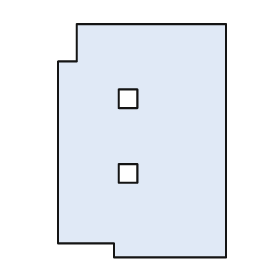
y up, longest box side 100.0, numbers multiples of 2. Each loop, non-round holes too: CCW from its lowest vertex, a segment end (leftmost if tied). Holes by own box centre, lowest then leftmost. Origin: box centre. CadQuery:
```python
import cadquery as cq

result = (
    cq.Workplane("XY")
    .moveTo(-12.0, -50.0)
    .lineTo(36.0, -50.0)
    .lineTo(36.0, 50.0)
    .lineTo(-28.0, 50.0)
    .lineTo(-28.0, 34.0)
    .lineTo(-36.0, 34.0)
    .lineTo(-36.0, -44.0)
    .lineTo(-12.0, -44.0)
    .close()
    .moveTo(-10.0, -18.0)
    .lineTo(-2.0, -18.0)
    .lineTo(-2.0, -10.0)
    .lineTo(-10.0, -10.0)
    .close()
    .moveTo(-10.0, 14.0)
    .lineTo(-2.0, 14.0)
    .lineTo(-2.0, 22.0)
    .lineTo(-10.0, 22.0)
    .close()
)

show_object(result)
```